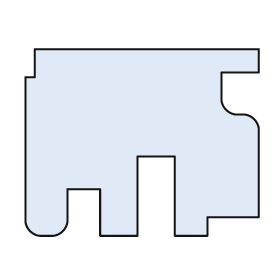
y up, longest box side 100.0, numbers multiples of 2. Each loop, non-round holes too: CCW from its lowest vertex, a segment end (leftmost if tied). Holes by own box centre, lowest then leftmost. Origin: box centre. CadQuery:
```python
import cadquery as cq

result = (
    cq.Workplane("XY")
    .moveTo(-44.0, -40.0)
    .lineTo(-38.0, -40.0)
    .threePointArc((-34.0, -38.0), (-32.0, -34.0))
    .lineTo(-32.0, -20.0)
    .lineTo(-18.0, -20.0)
    .lineTo(-18.0, -40.0)
    .lineTo(-2.0, -40.0)
    .lineTo(-2.0, -6.0)
    .lineTo(14.0, -6.0)
    .lineTo(14.0, -40.0)
    .lineTo(28.0, -40.0)
    .lineTo(28.0, -32.0)
    .lineTo(50.0, -32.0)
    .lineTo(50.0, 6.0)
    .threePointArc((48.0, 10.0), (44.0, 12.0))
    .lineTo(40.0, 12.0)
    .threePointArc((36.0, 14.0), (34.0, 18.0))
    .lineTo(34.0, 30.0)
    .lineTo(50.0, 30.0)
    .lineTo(50.0, 40.0)
    .lineTo(-46.0, 40.0)
    .lineTo(-46.0, 28.0)
    .lineTo(-50.0, 28.0)
    .lineTo(-50.0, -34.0)
    .threePointArc((-48.0, -38.0), (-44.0, -40.0))
    .close()
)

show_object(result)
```